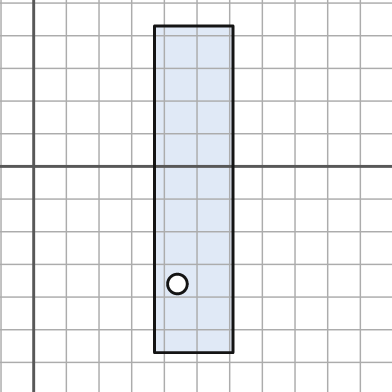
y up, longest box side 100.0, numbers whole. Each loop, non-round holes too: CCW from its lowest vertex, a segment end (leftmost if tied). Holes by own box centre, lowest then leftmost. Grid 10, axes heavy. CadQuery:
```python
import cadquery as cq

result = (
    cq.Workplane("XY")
    .moveTo(37.0, -57.0)
    .lineTo(61.0, -57.0)
    .lineTo(61.0, 43.0)
    .lineTo(37.0, 43.0)
    .close()
    .moveTo(44.0, -36.0)
    .circle(3.0)
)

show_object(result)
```